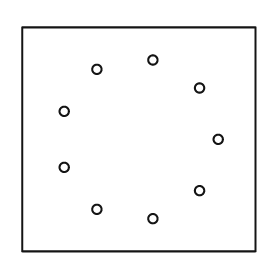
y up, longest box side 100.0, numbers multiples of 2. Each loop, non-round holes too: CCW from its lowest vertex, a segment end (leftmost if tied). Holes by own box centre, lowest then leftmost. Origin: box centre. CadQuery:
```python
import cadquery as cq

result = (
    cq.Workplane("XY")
    .moveTo(-50.0, -48.0)
    .lineTo(50.0, -48.0)
    .lineTo(50.0, 48.0)
    .lineTo(-50.0, 48.0)
    .close()
    .moveTo(6.0, -34.0)
    .circle(2.0)
    .moveTo(-18.0, -30.0)
    .circle(2.0)
    .moveTo(26.0, -22.0)
    .circle(2.0)
    .moveTo(-32.0, -12.0)
    .circle(2.0)
    .moveTo(34.0, 0.0)
    .circle(2.0)
    .moveTo(-32.0, 12.0)
    .circle(2.0)
    .moveTo(26.0, 22.0)
    .circle(2.0)
    .moveTo(-18.0, 30.0)
    .circle(2.0)
    .moveTo(6.0, 34.0)
    .circle(2.0)
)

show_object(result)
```